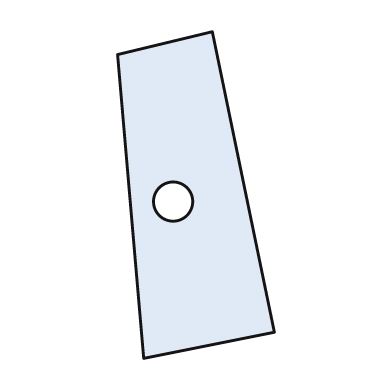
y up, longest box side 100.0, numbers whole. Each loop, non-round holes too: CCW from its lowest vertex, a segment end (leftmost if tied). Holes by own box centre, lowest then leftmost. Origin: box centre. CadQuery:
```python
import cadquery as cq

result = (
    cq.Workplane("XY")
    .moveTo(-16.0, -50.0)
    .lineTo(24.0, -42.0)
    .lineTo(5.0, 50.0)
    .lineTo(-24.0, 43.0)
    .close()
    .moveTo(-7.0, -2.0)
    .circle(6.0)
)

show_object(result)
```